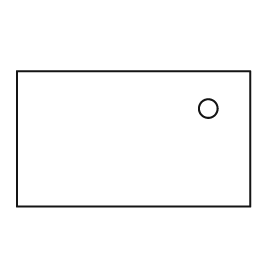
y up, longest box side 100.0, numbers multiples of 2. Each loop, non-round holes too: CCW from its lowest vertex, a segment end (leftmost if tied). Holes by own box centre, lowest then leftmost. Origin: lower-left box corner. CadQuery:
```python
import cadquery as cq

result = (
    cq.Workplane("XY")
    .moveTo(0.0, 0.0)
    .lineTo(100.0, 0.0)
    .lineTo(100.0, 58.0)
    .lineTo(0.0, 58.0)
    .close()
    .moveTo(82.0, 42.0)
    .circle(4.0)
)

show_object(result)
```